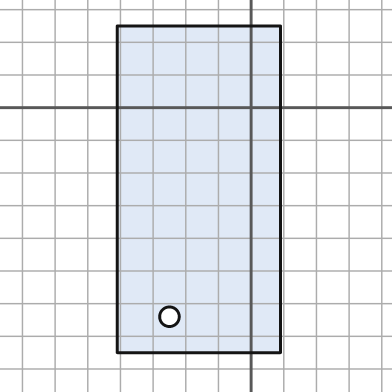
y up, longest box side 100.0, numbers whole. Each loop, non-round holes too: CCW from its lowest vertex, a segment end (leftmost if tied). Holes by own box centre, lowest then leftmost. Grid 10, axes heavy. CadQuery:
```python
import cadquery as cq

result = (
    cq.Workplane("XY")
    .moveTo(-41.0, -75.0)
    .lineTo(9.0, -75.0)
    .lineTo(9.0, 25.0)
    .lineTo(-41.0, 25.0)
    .close()
    .moveTo(-25.0, -64.0)
    .circle(3.0)
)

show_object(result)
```